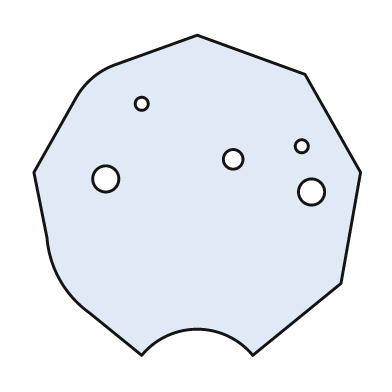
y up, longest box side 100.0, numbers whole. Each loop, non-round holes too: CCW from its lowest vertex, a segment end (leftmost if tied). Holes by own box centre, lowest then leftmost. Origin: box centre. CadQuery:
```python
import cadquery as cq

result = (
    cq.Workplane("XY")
    .moveTo(-17.0, -49.0)
    .threePointArc((0.0, -41.0), (17.0, -49.0))
    .lineTo(44.0, -27.0)
    .lineTo(50.0, 7.0)
    .lineTo(33.0, 37.0)
    .lineTo(0.0, 49.0)
    .lineTo(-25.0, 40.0)
    .threePointArc((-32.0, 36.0), (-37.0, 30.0))
    .lineTo(-50.0, 7.0)
    .lineTo(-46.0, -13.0)
    .threePointArc((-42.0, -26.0), (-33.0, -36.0))
    .close()
    .moveTo(35.0, 1.0)
    .circle(4.0)
    .moveTo(-28.0, 5.0)
    .circle(4.0)
    .moveTo(11.0, 11.0)
    .circle(3.0)
    .moveTo(32.0, 15.0)
    .circle(2.0)
    .moveTo(-17.0, 28.0)
    .circle(2.0)
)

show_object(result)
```